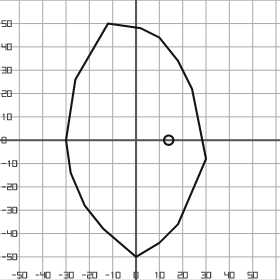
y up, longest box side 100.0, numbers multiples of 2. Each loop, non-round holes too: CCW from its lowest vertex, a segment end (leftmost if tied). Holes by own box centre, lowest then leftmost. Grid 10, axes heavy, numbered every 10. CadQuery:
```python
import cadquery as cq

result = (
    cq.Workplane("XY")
    .moveTo(0.0, -50.0)
    .lineTo(10.0, -44.0)
    .lineTo(18.0, -36.0)
    .lineTo(30.0, -8.0)
    .lineTo(24.0, 22.0)
    .lineTo(18.0, 34.0)
    .lineTo(10.0, 44.0)
    .lineTo(2.0, 48.0)
    .lineTo(-12.0, 50.0)
    .lineTo(-26.0, 26.0)
    .lineTo(-30.0, 0.0)
    .lineTo(-28.0, -14.0)
    .lineTo(-22.0, -28.0)
    .lineTo(-14.0, -38.0)
    .close()
    .moveTo(14.0, 0.0)
    .circle(2.0)
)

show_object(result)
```